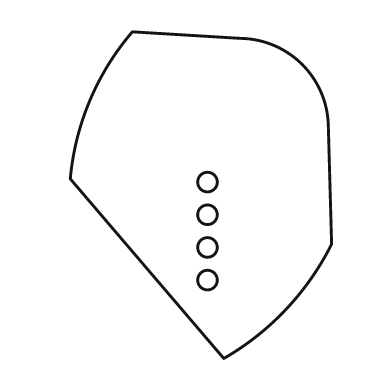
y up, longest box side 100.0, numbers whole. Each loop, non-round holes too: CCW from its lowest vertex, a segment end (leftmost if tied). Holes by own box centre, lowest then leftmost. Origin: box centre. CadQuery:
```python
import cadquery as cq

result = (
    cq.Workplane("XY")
    .moveTo(7.0, -50.0)
    .threePointArc((26.0, -35.0), (40.0, -15.0))
    .lineTo(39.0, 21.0)
    .threePointArc((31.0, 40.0), (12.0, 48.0))
    .lineTo(-21.0, 50.0)
    .threePointArc((-34.0, 29.0), (-40.0, 5.0))
    .close()
    .moveTo(2.0, -26.0)
    .circle(3.0)
    .moveTo(2.0, -16.0)
    .circle(3.0)
    .moveTo(2.0, -6.0)
    .circle(3.0)
    .moveTo(2.0, 4.0)
    .circle(3.0)
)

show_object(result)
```